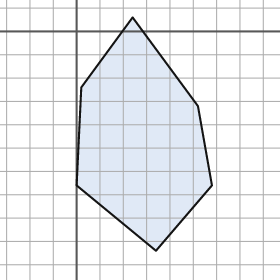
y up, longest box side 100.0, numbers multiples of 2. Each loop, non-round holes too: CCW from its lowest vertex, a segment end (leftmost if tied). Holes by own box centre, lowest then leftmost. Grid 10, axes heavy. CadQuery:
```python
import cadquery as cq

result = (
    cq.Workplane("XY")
    .moveTo(34.0, -94.0)
    .lineTo(58.0, -66.0)
    .lineTo(52.0, -32.0)
    .lineTo(24.0, 6.0)
    .lineTo(2.0, -24.0)
    .lineTo(0.0, -66.0)
    .close()
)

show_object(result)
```